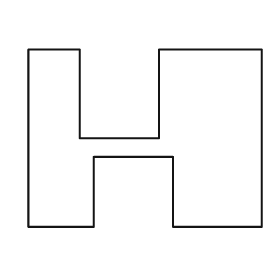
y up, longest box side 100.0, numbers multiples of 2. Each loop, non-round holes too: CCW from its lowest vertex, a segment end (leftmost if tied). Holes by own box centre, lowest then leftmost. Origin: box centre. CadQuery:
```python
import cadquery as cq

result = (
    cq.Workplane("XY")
    .moveTo(-50.0, -38.0)
    .lineTo(-22.0, -38.0)
    .lineTo(-22.0, -8.0)
    .lineTo(12.0, -8.0)
    .lineTo(12.0, -38.0)
    .lineTo(50.0, -38.0)
    .lineTo(50.0, 38.0)
    .lineTo(6.0, 38.0)
    .lineTo(6.0, 0.0)
    .lineTo(-28.0, 0.0)
    .lineTo(-28.0, 38.0)
    .lineTo(-50.0, 38.0)
    .close()
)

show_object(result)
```